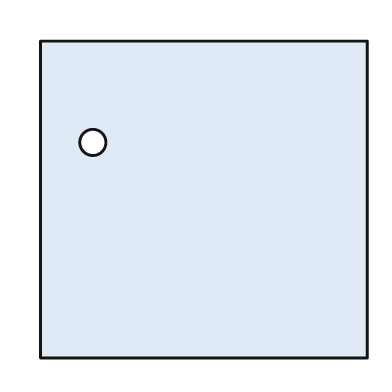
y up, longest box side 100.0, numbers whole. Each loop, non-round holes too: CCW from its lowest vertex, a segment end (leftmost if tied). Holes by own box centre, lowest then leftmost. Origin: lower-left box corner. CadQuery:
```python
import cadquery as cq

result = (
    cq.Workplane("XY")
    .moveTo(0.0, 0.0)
    .lineTo(100.0, 0.0)
    .lineTo(100.0, 97.0)
    .lineTo(0.0, 97.0)
    .close()
    .moveTo(16.0, 66.0)
    .circle(4.0)
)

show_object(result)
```